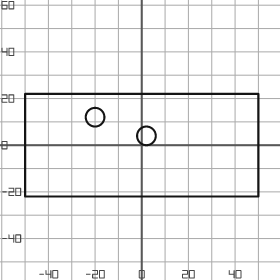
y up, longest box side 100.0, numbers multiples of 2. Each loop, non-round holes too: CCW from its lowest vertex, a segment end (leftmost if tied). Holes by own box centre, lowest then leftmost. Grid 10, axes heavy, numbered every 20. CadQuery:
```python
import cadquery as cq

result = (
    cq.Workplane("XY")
    .moveTo(-50.0, -22.0)
    .lineTo(50.0, -22.0)
    .lineTo(50.0, 22.0)
    .lineTo(-50.0, 22.0)
    .close()
    .moveTo(2.0, 4.0)
    .circle(4.0)
    .moveTo(-20.0, 12.0)
    .circle(4.0)
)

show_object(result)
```